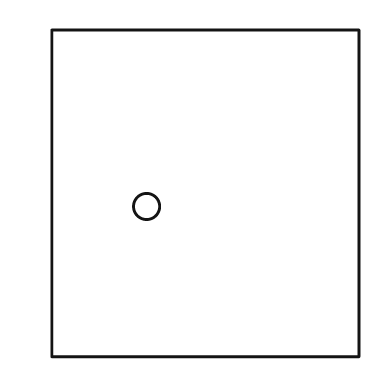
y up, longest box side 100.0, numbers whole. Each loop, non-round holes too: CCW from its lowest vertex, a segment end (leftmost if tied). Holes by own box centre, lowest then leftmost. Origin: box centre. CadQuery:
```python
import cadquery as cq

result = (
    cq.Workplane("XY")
    .moveTo(-47.0, -50.0)
    .lineTo(47.0, -50.0)
    .lineTo(47.0, 50.0)
    .lineTo(-47.0, 50.0)
    .close()
    .moveTo(-18.0, -4.0)
    .circle(4.0)
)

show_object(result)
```